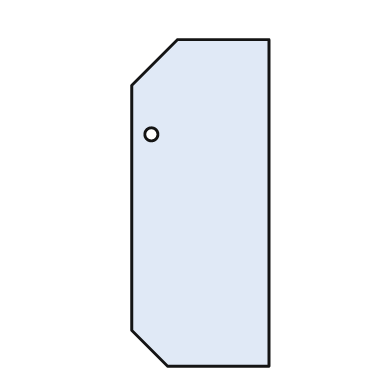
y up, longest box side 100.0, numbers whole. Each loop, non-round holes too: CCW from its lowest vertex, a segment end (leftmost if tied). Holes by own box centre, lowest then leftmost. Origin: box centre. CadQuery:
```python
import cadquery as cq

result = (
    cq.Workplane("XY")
    .moveTo(-10.0, -50.0)
    .lineTo(21.0, -50.0)
    .lineTo(21.0, 50.0)
    .lineTo(-7.0, 50.0)
    .lineTo(-21.0, 36.0)
    .lineTo(-21.0, -39.0)
    .close()
    .moveTo(-15.0, 21.0)
    .circle(2.0)
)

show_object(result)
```